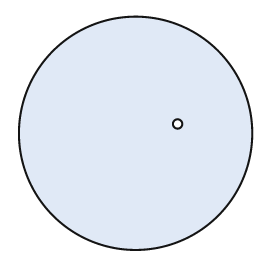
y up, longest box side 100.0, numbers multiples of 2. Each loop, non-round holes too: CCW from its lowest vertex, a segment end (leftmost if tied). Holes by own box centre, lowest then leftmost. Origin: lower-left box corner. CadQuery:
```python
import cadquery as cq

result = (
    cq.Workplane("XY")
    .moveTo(50.0, 50.0)
    .circle(50.0)
    .moveTo(68.0, 54.0)
    .circle(2.0)
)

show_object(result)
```